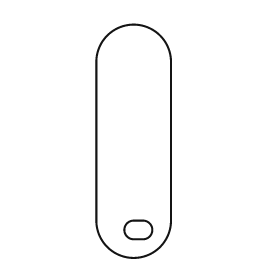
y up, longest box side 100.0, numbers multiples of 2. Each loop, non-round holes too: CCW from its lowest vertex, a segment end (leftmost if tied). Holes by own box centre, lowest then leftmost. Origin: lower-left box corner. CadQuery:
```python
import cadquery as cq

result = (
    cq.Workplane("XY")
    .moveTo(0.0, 16.0)
    .threePointArc((16.0, 0.0), (32.0, 16.0))
    .lineTo(32.0, 84.0)
    .threePointArc((16.0, 100.0), (0.0, 84.0))
    .close()
    .moveTo(16.0, 8.0)
    .lineTo(20.0, 8.0)
    .threePointArc((24.0, 12.0), (20.0, 16.0))
    .lineTo(16.0, 16.0)
    .threePointArc((12.0, 12.0), (16.0, 8.0))
    .close()
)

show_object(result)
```